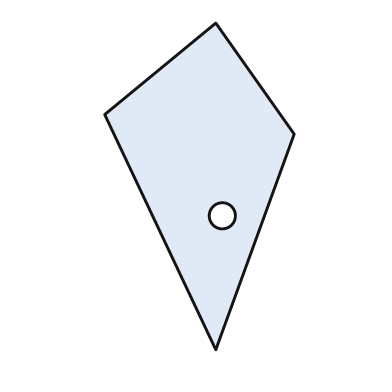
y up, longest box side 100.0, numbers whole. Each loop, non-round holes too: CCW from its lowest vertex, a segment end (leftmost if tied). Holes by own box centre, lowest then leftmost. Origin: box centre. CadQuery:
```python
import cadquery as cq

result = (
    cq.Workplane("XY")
    .moveTo(5.0, -50.0)
    .lineTo(29.0, 16.0)
    .lineTo(5.0, 50.0)
    .lineTo(-29.0, 22.0)
    .close()
    .moveTo(7.0, -9.0)
    .circle(4.0)
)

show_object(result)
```